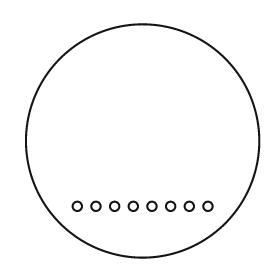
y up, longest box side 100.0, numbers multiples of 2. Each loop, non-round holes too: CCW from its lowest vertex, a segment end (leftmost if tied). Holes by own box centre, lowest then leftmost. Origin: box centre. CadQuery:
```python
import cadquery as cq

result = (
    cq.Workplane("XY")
    .moveTo(0.0, 0.0)
    .circle(50.0)
    .moveTo(-28.0, -28.0)
    .circle(2.0)
    .moveTo(-20.0, -28.0)
    .circle(2.0)
    .moveTo(-12.0, -28.0)
    .circle(2.0)
    .moveTo(-4.0, -28.0)
    .circle(2.0)
    .moveTo(4.0, -28.0)
    .circle(2.0)
    .moveTo(12.0, -28.0)
    .circle(2.0)
    .moveTo(20.0, -28.0)
    .circle(2.0)
    .moveTo(28.0, -28.0)
    .circle(2.0)
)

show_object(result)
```